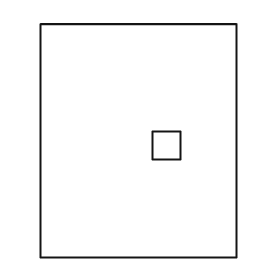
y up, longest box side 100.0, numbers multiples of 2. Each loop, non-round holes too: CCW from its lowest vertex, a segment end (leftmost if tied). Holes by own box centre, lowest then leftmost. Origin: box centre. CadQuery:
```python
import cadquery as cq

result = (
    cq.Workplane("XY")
    .moveTo(-42.0, -50.0)
    .lineTo(42.0, -50.0)
    .lineTo(42.0, 50.0)
    .lineTo(-42.0, 50.0)
    .close()
    .moveTo(6.0, -8.0)
    .lineTo(18.0, -8.0)
    .lineTo(18.0, 4.0)
    .lineTo(6.0, 4.0)
    .close()
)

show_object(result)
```